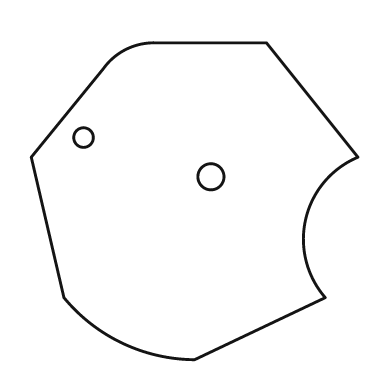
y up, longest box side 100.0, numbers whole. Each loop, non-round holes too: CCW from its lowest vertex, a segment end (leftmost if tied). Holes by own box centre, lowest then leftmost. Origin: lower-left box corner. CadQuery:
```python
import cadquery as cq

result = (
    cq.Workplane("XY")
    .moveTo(50.0, 0.0)
    .lineTo(90.0, 19.0)
    .threePointArc((84.0, 43.0), (100.0, 62.0))
    .lineTo(72.0, 97.0)
    .lineTo(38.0, 97.0)
    .threePointArc((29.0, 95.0), (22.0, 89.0))
    .lineTo(0.0, 62.0)
    .lineTo(10.0, 19.0)
    .threePointArc((28.0, 5.0), (50.0, 0.0))
    .close()
    .moveTo(55.0, 56.0)
    .circle(4.0)
    .moveTo(16.0, 68.0)
    .circle(3.0)
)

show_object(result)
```